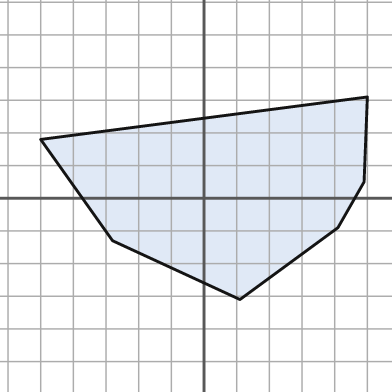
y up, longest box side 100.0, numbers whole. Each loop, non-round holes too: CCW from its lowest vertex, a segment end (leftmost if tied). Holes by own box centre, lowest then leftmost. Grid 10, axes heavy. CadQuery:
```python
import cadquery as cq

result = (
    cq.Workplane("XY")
    .moveTo(11.0, -31.0)
    .lineTo(41.0, -9.0)
    .lineTo(49.0, 5.0)
    .lineTo(50.0, 31.0)
    .lineTo(-50.0, 18.0)
    .lineTo(-28.0, -13.0)
    .close()
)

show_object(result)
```